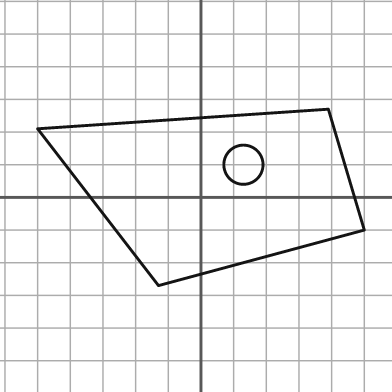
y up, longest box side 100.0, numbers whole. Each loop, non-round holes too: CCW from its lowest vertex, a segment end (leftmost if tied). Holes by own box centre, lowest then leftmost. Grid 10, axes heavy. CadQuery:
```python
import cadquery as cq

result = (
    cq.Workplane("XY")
    .moveTo(-13.0, -27.0)
    .lineTo(50.0, -10.0)
    .lineTo(39.0, 27.0)
    .lineTo(-50.0, 21.0)
    .close()
    .moveTo(13.0, 10.0)
    .circle(6.0)
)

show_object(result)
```